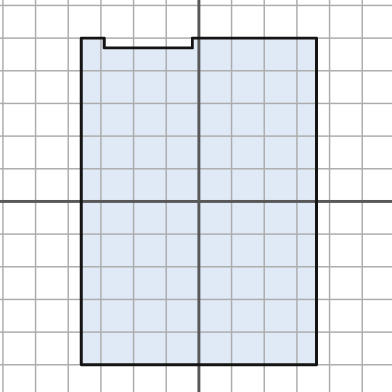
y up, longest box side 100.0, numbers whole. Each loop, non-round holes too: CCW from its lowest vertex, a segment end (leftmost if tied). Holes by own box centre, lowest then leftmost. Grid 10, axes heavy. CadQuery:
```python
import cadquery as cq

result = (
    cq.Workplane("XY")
    .moveTo(-36.0, -50.0)
    .lineTo(36.0, -50.0)
    .lineTo(36.0, 50.0)
    .lineTo(-2.0, 50.0)
    .lineTo(-2.0, 47.0)
    .lineTo(-29.0, 47.0)
    .lineTo(-29.0, 50.0)
    .lineTo(-36.0, 50.0)
    .close()
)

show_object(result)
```